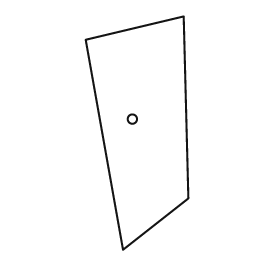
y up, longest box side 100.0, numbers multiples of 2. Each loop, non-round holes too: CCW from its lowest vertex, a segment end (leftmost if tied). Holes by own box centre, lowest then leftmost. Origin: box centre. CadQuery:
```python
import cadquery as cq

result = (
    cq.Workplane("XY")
    .moveTo(-6.0, -50.0)
    .lineTo(22.0, -28.0)
    .lineTo(20.0, 50.0)
    .lineTo(-22.0, 40.0)
    .close()
    .moveTo(-2.0, 6.0)
    .circle(2.0)
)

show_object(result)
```